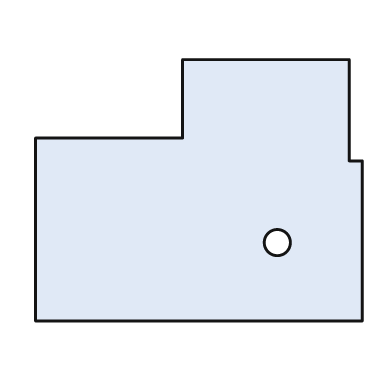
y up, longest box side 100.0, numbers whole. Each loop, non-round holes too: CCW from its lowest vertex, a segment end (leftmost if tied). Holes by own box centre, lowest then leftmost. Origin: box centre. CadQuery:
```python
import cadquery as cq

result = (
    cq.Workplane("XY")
    .moveTo(-50.0, -40.0)
    .lineTo(50.0, -40.0)
    .lineTo(50.0, 9.0)
    .lineTo(46.0, 9.0)
    .lineTo(46.0, 40.0)
    .lineTo(-5.0, 40.0)
    .lineTo(-5.0, 16.0)
    .lineTo(-50.0, 16.0)
    .close()
    .moveTo(24.0, -16.0)
    .circle(4.0)
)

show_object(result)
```